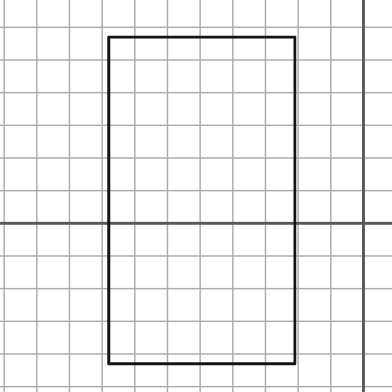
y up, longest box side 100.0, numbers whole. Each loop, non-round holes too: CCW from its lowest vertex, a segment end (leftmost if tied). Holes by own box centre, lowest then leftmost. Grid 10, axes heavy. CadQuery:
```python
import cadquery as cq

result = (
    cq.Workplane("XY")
    .moveTo(-78.0, -43.0)
    .lineTo(-21.0, -43.0)
    .lineTo(-21.0, 57.0)
    .lineTo(-78.0, 57.0)
    .close()
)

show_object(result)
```